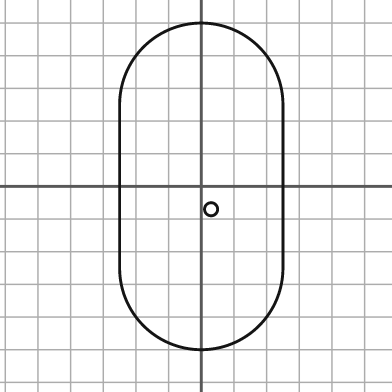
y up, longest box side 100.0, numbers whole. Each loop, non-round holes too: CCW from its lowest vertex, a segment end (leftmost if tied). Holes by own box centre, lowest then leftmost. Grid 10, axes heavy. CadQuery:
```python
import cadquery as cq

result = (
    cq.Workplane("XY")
    .moveTo(-25.0, -25.0)
    .threePointArc((0.0, -50.0), (25.0, -25.0))
    .lineTo(25.0, 25.0)
    .threePointArc((0.0, 50.0), (-25.0, 25.0))
    .close()
    .moveTo(3.0, -7.0)
    .circle(2.0)
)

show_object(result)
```